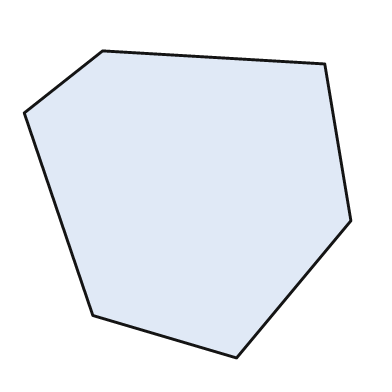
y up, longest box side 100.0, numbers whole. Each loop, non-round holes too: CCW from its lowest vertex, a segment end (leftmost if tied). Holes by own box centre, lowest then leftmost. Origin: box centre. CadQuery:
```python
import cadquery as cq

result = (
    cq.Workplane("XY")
    .moveTo(15.0, -47.0)
    .lineTo(50.0, -5.0)
    .lineTo(42.0, 43.0)
    .lineTo(-26.0, 47.0)
    .lineTo(-50.0, 28.0)
    .lineTo(-29.0, -34.0)
    .close()
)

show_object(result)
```